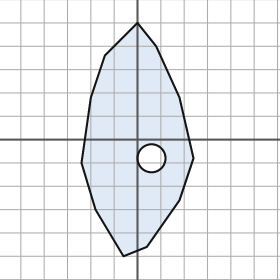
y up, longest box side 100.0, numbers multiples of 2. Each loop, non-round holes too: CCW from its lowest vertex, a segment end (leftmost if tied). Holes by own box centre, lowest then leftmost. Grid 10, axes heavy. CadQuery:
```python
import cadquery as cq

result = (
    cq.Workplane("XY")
    .moveTo(-6.0, -50.0)
    .lineTo(4.0, -46.0)
    .lineTo(18.0, -26.0)
    .lineTo(24.0, -8.0)
    .lineTo(18.0, 18.0)
    .lineTo(8.0, 40.0)
    .lineTo(0.0, 50.0)
    .lineTo(-14.0, 36.0)
    .lineTo(-20.0, 18.0)
    .lineTo(-24.0, -10.0)
    .lineTo(-18.0, -30.0)
    .close()
    .moveTo(6.0, -8.0)
    .circle(6.0)
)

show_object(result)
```